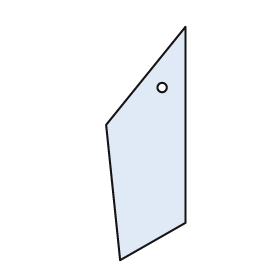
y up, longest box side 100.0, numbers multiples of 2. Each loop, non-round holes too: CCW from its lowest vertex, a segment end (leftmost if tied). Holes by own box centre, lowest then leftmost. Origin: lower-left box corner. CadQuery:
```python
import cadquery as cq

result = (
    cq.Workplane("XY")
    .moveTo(6.0, 0.0)
    .lineTo(34.0, 16.0)
    .lineTo(34.0, 100.0)
    .lineTo(0.0, 58.0)
    .close()
    .moveTo(24.0, 74.0)
    .circle(2.0)
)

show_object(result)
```